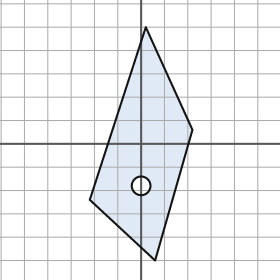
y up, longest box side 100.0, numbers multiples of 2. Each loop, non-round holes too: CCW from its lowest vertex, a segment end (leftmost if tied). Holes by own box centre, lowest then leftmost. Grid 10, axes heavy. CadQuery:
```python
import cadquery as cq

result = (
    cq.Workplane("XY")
    .moveTo(6.0, -50.0)
    .lineTo(22.0, 6.0)
    .lineTo(2.0, 50.0)
    .lineTo(-22.0, -24.0)
    .close()
    .moveTo(0.0, -18.0)
    .circle(4.0)
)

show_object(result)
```